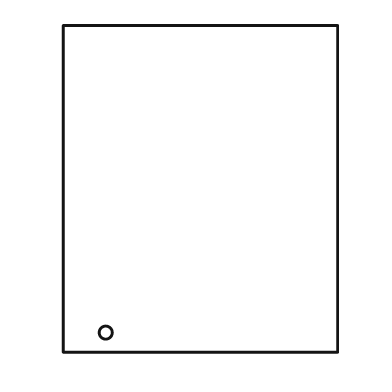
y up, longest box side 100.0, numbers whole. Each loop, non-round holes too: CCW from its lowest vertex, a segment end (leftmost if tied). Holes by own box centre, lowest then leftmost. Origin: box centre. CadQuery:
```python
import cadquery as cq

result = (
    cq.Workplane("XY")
    .moveTo(-42.0, -50.0)
    .lineTo(42.0, -50.0)
    .lineTo(42.0, 50.0)
    .lineTo(-42.0, 50.0)
    .close()
    .moveTo(-29.0, -44.0)
    .circle(2.0)
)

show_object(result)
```